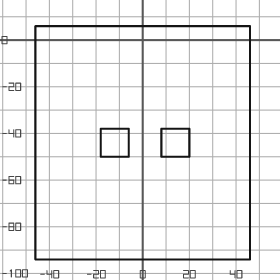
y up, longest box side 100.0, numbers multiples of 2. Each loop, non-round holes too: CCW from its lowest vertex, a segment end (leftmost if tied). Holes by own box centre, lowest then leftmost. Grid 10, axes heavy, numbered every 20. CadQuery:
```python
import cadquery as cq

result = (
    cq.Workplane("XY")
    .moveTo(-46.0, -94.0)
    .lineTo(46.0, -94.0)
    .lineTo(46.0, 6.0)
    .lineTo(-46.0, 6.0)
    .close()
    .moveTo(-18.0, -50.0)
    .lineTo(-6.0, -50.0)
    .lineTo(-6.0, -38.0)
    .lineTo(-18.0, -38.0)
    .close()
    .moveTo(8.0, -50.0)
    .lineTo(20.0, -50.0)
    .lineTo(20.0, -38.0)
    .lineTo(8.0, -38.0)
    .close()
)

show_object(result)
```